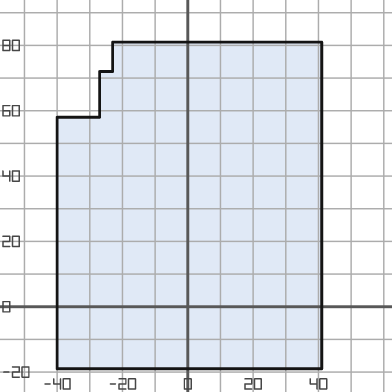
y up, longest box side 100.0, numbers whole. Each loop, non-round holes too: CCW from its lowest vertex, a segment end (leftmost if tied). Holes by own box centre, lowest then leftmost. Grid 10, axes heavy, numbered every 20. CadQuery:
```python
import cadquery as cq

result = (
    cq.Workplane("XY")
    .moveTo(-40.0, -19.0)
    .lineTo(41.0, -19.0)
    .lineTo(41.0, 81.0)
    .lineTo(-23.0, 81.0)
    .lineTo(-23.0, 72.0)
    .lineTo(-27.0, 72.0)
    .lineTo(-27.0, 58.0)
    .lineTo(-40.0, 58.0)
    .close()
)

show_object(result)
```